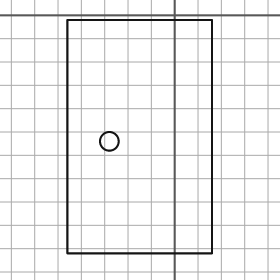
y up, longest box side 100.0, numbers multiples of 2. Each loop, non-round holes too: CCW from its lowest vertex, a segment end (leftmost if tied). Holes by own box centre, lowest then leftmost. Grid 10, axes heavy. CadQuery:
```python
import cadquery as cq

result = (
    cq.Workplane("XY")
    .moveTo(-46.0, -102.0)
    .lineTo(16.0, -102.0)
    .lineTo(16.0, -2.0)
    .lineTo(-46.0, -2.0)
    .close()
    .moveTo(-28.0, -54.0)
    .circle(4.0)
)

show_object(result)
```